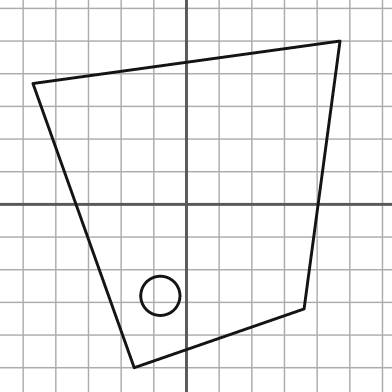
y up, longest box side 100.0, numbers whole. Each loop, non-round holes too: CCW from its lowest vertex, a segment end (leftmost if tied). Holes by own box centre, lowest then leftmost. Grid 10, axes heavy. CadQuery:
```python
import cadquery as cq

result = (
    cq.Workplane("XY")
    .moveTo(-16.0, -50.0)
    .lineTo(36.0, -32.0)
    .lineTo(47.0, 50.0)
    .lineTo(-47.0, 37.0)
    .close()
    .moveTo(-8.0, -28.0)
    .circle(6.0)
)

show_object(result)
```